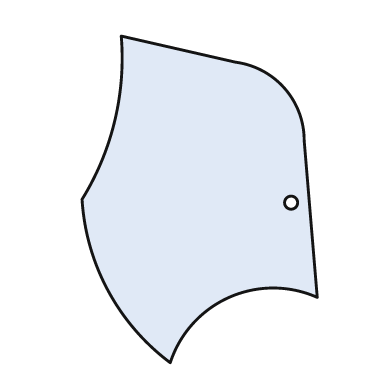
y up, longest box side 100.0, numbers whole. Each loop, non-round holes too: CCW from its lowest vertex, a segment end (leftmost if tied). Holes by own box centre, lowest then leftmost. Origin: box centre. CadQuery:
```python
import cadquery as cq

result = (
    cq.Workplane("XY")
    .moveTo(-9.0, -50.0)
    .threePointArc((9.0, -30.0), (36.0, -30.0))
    .lineTo(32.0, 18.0)
    .threePointArc((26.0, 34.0), (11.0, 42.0))
    .lineTo(-24.0, 50.0)
    .threePointArc((-26.0, 24.0), (-36.0, 0.0))
    .threePointArc((-28.0, -28.0), (-9.0, -50.0))
    .close()
    .moveTo(28.0, -1.0)
    .circle(2.0)
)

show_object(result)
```